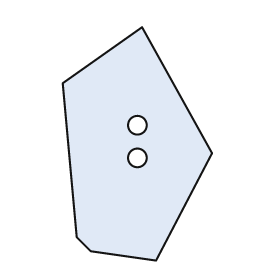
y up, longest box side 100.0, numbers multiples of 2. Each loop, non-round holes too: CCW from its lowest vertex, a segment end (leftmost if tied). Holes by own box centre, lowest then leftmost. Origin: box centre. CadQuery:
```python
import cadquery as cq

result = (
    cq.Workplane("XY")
    .moveTo(8.0, -50.0)
    .lineTo(32.0, -4.0)
    .lineTo(2.0, 50.0)
    .lineTo(-32.0, 26.0)
    .lineTo(-26.0, -40.0)
    .lineTo(-20.0, -46.0)
    .close()
    .moveTo(0.0, -6.0)
    .circle(4.0)
    .moveTo(0.0, 8.0)
    .circle(4.0)
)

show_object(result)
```